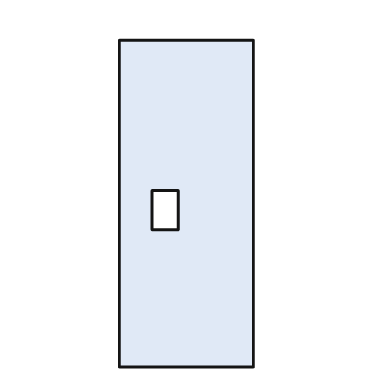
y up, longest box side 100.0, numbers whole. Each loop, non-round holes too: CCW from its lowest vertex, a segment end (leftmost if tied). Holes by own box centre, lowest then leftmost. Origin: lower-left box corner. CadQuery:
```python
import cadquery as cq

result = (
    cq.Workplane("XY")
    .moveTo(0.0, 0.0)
    .lineTo(41.0, 0.0)
    .lineTo(41.0, 100.0)
    .lineTo(0.0, 100.0)
    .close()
    .moveTo(10.0, 42.0)
    .lineTo(18.0, 42.0)
    .lineTo(18.0, 54.0)
    .lineTo(10.0, 54.0)
    .close()
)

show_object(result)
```